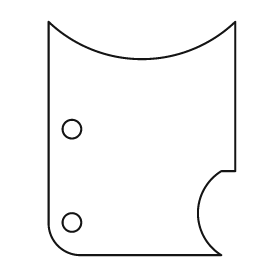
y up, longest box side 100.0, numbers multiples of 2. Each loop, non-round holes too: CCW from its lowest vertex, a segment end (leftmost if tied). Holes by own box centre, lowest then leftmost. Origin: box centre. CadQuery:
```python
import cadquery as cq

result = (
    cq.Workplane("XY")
    .moveTo(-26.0, -50.0)
    .lineTo(34.0, -50.0)
    .threePointArc((24.0, -32.0), (34.0, -14.0))
    .lineTo(40.0, -14.0)
    .lineTo(40.0, 50.0)
    .threePointArc((0.0, 34.0), (-40.0, 50.0))
    .lineTo(-40.0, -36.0)
    .threePointArc((-36.0, -46.0), (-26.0, -50.0))
    .close()
    .moveTo(-30.0, -36.0)
    .circle(4.0)
    .moveTo(-30.0, 4.0)
    .circle(4.0)
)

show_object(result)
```